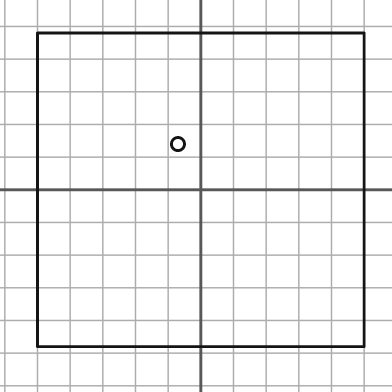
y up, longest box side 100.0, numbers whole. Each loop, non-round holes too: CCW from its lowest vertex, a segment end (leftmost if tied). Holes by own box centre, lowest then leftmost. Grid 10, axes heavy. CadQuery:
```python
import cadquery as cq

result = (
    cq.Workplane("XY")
    .moveTo(-50.0, -48.0)
    .lineTo(50.0, -48.0)
    .lineTo(50.0, 48.0)
    .lineTo(-50.0, 48.0)
    .close()
    .moveTo(-7.0, 14.0)
    .circle(2.0)
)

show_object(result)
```